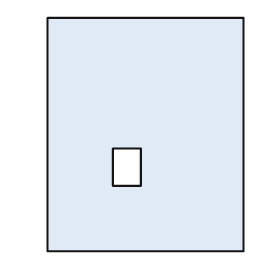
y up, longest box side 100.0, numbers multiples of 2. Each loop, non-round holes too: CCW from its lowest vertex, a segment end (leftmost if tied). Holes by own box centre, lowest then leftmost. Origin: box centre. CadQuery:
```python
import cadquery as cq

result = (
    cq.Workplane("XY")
    .moveTo(-42.0, -50.0)
    .lineTo(42.0, -50.0)
    .lineTo(42.0, 50.0)
    .lineTo(-42.0, 50.0)
    .close()
    .moveTo(-14.0, -22.0)
    .lineTo(-2.0, -22.0)
    .lineTo(-2.0, -6.0)
    .lineTo(-14.0, -6.0)
    .close()
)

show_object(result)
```